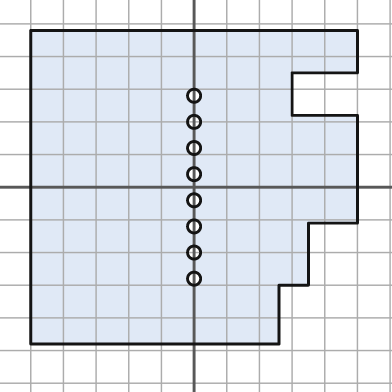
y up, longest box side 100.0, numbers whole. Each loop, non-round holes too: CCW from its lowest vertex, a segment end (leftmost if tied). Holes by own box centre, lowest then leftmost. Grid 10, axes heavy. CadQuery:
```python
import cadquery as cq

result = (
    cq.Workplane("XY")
    .moveTo(-50.0, -48.0)
    .lineTo(26.0, -48.0)
    .lineTo(26.0, -30.0)
    .lineTo(35.0, -30.0)
    .lineTo(35.0, -11.0)
    .lineTo(50.0, -11.0)
    .lineTo(50.0, 22.0)
    .lineTo(30.0, 22.0)
    .lineTo(30.0, 35.0)
    .lineTo(50.0, 35.0)
    .lineTo(50.0, 48.0)
    .lineTo(-50.0, 48.0)
    .close()
    .moveTo(0.0, -28.0)
    .circle(2.0)
    .moveTo(0.0, -20.0)
    .circle(2.0)
    .moveTo(0.0, -12.0)
    .circle(2.0)
    .moveTo(0.0, -4.0)
    .circle(2.0)
    .moveTo(0.0, 4.0)
    .circle(2.0)
    .moveTo(0.0, 12.0)
    .circle(2.0)
    .moveTo(0.0, 20.0)
    .circle(2.0)
    .moveTo(0.0, 28.0)
    .circle(2.0)
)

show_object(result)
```